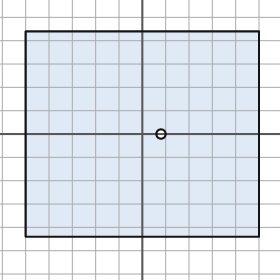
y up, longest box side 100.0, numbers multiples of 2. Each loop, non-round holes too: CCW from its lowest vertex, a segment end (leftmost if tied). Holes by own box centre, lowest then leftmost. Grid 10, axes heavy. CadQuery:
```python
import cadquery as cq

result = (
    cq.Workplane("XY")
    .moveTo(-50.0, -44.0)
    .lineTo(50.0, -44.0)
    .lineTo(50.0, 44.0)
    .lineTo(-50.0, 44.0)
    .close()
    .moveTo(8.0, 0.0)
    .circle(2.0)
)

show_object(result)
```